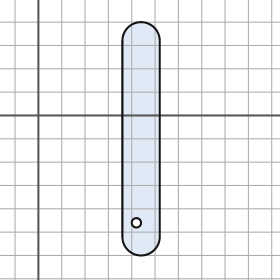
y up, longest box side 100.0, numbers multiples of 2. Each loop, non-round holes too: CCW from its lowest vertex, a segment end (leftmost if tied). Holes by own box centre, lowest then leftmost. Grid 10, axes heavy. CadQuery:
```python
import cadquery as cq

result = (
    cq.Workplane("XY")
    .moveTo(36.0, -52.0)
    .threePointArc((44.0, -60.0), (52.0, -52.0))
    .lineTo(52.0, 32.0)
    .threePointArc((44.0, 40.0), (36.0, 32.0))
    .close()
    .moveTo(42.0, -46.0)
    .circle(2.0)
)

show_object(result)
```